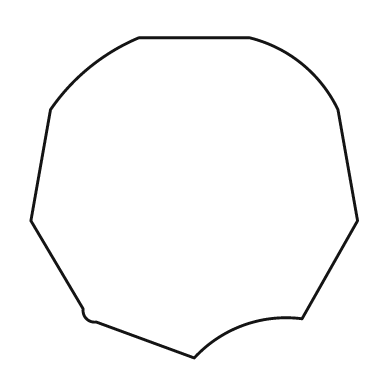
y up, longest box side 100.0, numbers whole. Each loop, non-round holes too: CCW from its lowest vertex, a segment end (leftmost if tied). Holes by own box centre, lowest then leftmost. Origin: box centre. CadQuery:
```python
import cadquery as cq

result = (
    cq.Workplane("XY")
    .moveTo(0.0, -49.0)
    .threePointArc((15.0, -39.0), (33.0, -37.0))
    .lineTo(50.0, -7.0)
    .lineTo(44.0, 27.0)
    .threePointArc((33.0, 41.0), (17.0, 49.0))
    .lineTo(-17.0, 49.0)
    .threePointArc((-32.0, 40.0), (-44.0, 27.0))
    .lineTo(-50.0, -7.0)
    .lineTo(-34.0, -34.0)
    .threePointArc((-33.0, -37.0), (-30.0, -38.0))
    .close()
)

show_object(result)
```